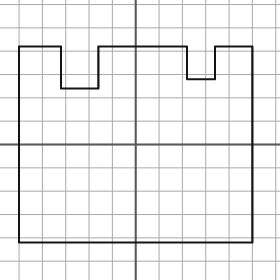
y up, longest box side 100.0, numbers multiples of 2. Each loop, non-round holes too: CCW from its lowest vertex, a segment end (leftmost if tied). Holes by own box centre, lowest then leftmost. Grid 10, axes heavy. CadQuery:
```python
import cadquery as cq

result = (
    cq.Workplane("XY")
    .moveTo(-50.0, -42.0)
    .lineTo(50.0, -42.0)
    .lineTo(50.0, 42.0)
    .lineTo(34.0, 42.0)
    .lineTo(34.0, 28.0)
    .lineTo(22.0, 28.0)
    .lineTo(22.0, 42.0)
    .lineTo(-16.0, 42.0)
    .lineTo(-16.0, 24.0)
    .lineTo(-32.0, 24.0)
    .lineTo(-32.0, 42.0)
    .lineTo(-50.0, 42.0)
    .close()
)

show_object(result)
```